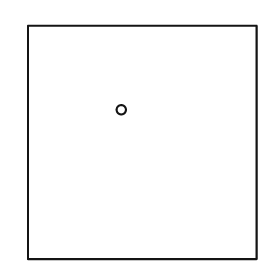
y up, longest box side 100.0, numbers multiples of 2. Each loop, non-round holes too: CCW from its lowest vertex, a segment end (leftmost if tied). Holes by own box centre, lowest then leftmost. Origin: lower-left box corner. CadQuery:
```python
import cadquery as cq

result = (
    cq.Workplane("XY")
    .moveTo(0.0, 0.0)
    .lineTo(98.0, 0.0)
    .lineTo(98.0, 100.0)
    .lineTo(0.0, 100.0)
    .close()
    .moveTo(40.0, 64.0)
    .circle(2.0)
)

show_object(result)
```